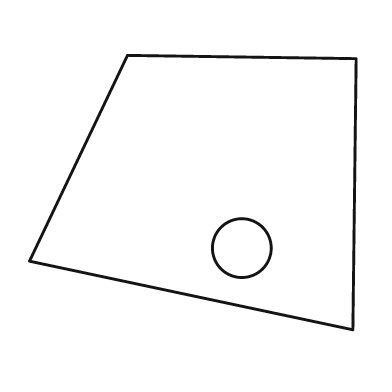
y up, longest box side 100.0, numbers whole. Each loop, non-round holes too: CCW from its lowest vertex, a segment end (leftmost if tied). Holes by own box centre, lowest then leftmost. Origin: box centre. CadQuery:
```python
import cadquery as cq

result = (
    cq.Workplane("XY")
    .moveTo(49.0, -42.0)
    .lineTo(50.0, 41.0)
    .lineTo(-20.0, 42.0)
    .lineTo(-50.0, -21.0)
    .close()
    .moveTo(15.0, -17.0)
    .circle(9.0)
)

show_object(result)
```